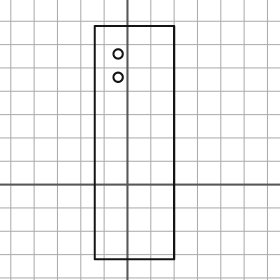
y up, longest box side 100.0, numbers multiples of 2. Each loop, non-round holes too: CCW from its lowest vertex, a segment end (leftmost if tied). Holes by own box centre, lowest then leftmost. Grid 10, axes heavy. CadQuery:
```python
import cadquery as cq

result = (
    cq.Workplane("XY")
    .moveTo(-14.0, -32.0)
    .lineTo(20.0, -32.0)
    .lineTo(20.0, 68.0)
    .lineTo(-14.0, 68.0)
    .close()
    .moveTo(-4.0, 46.0)
    .circle(2.0)
    .moveTo(-4.0, 56.0)
    .circle(2.0)
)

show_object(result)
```